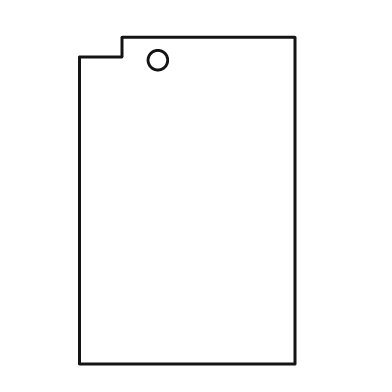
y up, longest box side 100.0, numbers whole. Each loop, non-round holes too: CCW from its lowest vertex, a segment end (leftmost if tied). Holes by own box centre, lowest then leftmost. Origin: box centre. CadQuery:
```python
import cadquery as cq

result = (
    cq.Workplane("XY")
    .moveTo(-33.0, -50.0)
    .lineTo(33.0, -50.0)
    .lineTo(33.0, 50.0)
    .lineTo(-20.0, 50.0)
    .lineTo(-20.0, 44.0)
    .lineTo(-33.0, 44.0)
    .close()
    .moveTo(-9.0, 43.0)
    .circle(3.0)
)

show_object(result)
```